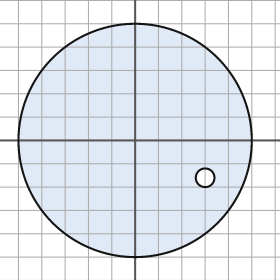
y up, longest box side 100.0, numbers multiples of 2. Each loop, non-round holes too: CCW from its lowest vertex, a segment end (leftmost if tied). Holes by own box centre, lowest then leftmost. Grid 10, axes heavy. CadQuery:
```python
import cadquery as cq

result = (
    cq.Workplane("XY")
    .moveTo(0.0, 0.0)
    .circle(50.0)
    .moveTo(30.0, -16.0)
    .circle(4.0)
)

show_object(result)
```